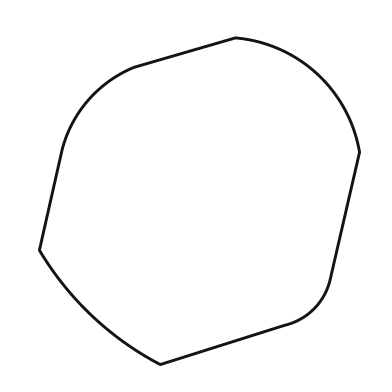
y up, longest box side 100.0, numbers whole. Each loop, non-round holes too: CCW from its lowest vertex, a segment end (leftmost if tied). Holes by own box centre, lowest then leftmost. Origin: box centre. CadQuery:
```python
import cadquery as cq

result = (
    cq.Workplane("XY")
    .moveTo(-12.0, -50.0)
    .lineTo(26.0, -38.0)
    .threePointArc((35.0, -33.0), (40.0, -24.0))
    .lineTo(49.0, 15.0)
    .threePointArc((36.0, 39.0), (11.0, 50.0))
    .lineTo(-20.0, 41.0)
    .threePointArc((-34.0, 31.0), (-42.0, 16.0))
    .lineTo(-49.0, -15.0)
    .threePointArc((-33.0, -35.0), (-12.0, -50.0))
    .close()
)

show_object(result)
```